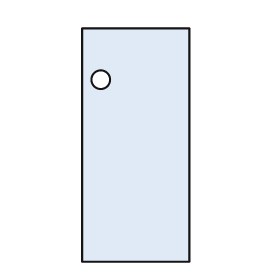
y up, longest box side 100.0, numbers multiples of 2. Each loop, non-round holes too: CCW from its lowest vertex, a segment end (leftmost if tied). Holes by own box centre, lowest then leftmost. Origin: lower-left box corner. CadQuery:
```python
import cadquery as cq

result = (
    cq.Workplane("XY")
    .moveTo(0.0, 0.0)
    .lineTo(46.0, 0.0)
    .lineTo(46.0, 100.0)
    .lineTo(0.0, 100.0)
    .close()
    .moveTo(8.0, 78.0)
    .circle(4.0)
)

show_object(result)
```